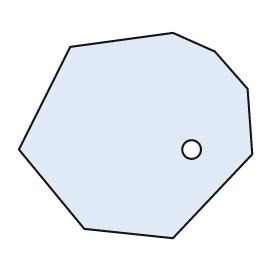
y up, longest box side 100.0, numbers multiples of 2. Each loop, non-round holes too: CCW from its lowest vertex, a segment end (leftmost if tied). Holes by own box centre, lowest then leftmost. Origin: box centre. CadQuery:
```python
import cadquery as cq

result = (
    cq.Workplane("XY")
    .moveTo(16.0, -44.0)
    .lineTo(50.0, -8.0)
    .lineTo(48.0, 20.0)
    .lineTo(34.0, 36.0)
    .lineTo(16.0, 44.0)
    .lineTo(-28.0, 38.0)
    .lineTo(-50.0, -6.0)
    .lineTo(-22.0, -40.0)
    .close()
    .moveTo(24.0, -6.0)
    .circle(4.0)
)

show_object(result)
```